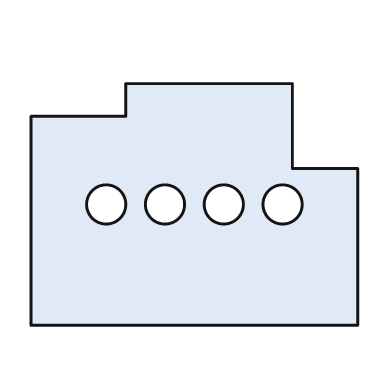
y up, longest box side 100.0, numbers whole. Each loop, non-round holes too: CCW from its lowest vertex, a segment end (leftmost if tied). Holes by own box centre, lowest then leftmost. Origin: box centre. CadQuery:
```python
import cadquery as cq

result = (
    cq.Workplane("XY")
    .moveTo(-50.0, -37.0)
    .lineTo(50.0, -37.0)
    .lineTo(50.0, 11.0)
    .lineTo(30.0, 11.0)
    .lineTo(30.0, 37.0)
    .lineTo(-21.0, 37.0)
    .lineTo(-21.0, 27.0)
    .lineTo(-50.0, 27.0)
    .close()
    .moveTo(-27.0, 0.0)
    .circle(6.0)
    .moveTo(-9.0, 0.0)
    .circle(6.0)
    .moveTo(9.0, 0.0)
    .circle(6.0)
    .moveTo(27.0, 0.0)
    .circle(6.0)
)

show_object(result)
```